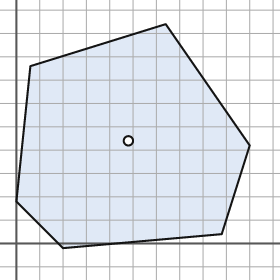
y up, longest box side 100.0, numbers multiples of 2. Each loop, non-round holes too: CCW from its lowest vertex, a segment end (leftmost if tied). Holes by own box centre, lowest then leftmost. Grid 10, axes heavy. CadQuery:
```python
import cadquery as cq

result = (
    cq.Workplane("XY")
    .moveTo(20.0, -2.0)
    .lineTo(88.0, 4.0)
    .lineTo(100.0, 42.0)
    .lineTo(64.0, 94.0)
    .lineTo(6.0, 76.0)
    .lineTo(0.0, 18.0)
    .close()
    .moveTo(48.0, 44.0)
    .circle(2.0)
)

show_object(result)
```